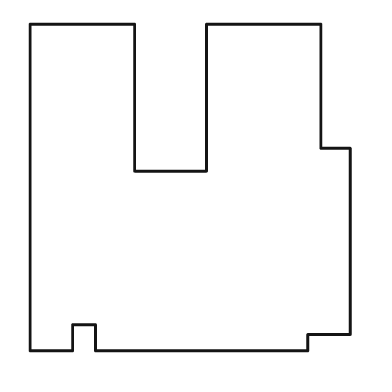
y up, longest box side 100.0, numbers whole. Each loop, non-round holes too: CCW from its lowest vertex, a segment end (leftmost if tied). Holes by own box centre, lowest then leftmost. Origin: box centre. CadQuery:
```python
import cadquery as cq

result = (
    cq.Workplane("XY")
    .moveTo(-49.0, -50.0)
    .lineTo(-36.0, -50.0)
    .lineTo(-36.0, -42.0)
    .lineTo(-29.0, -42.0)
    .lineTo(-29.0, -50.0)
    .lineTo(36.0, -50.0)
    .lineTo(36.0, -45.0)
    .lineTo(49.0, -45.0)
    .lineTo(49.0, 12.0)
    .lineTo(40.0, 12.0)
    .lineTo(40.0, 50.0)
    .lineTo(5.0, 50.0)
    .lineTo(5.0, 5.0)
    .lineTo(-17.0, 5.0)
    .lineTo(-17.0, 50.0)
    .lineTo(-49.0, 50.0)
    .close()
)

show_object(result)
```